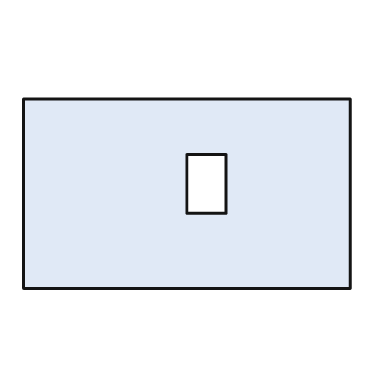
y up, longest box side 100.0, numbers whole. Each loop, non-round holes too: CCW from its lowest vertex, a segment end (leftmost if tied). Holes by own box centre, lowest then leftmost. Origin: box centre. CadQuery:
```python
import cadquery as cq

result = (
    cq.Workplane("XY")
    .moveTo(-50.0, -29.0)
    .lineTo(50.0, -29.0)
    .lineTo(50.0, 29.0)
    .lineTo(-50.0, 29.0)
    .close()
    .moveTo(0.0, -6.0)
    .lineTo(12.0, -6.0)
    .lineTo(12.0, 12.0)
    .lineTo(0.0, 12.0)
    .close()
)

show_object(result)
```